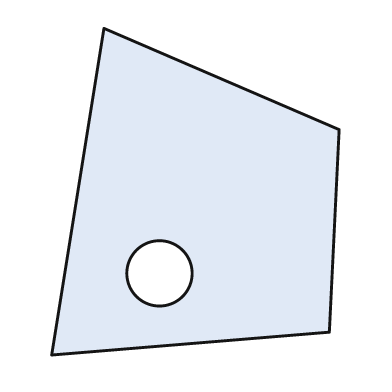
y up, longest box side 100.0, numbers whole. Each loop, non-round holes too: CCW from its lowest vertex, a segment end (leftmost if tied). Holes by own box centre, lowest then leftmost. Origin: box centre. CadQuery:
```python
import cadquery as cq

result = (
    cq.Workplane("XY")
    .moveTo(-44.0, -50.0)
    .lineTo(41.0, -43.0)
    .lineTo(44.0, 19.0)
    .lineTo(-28.0, 50.0)
    .close()
    .moveTo(-11.0, -25.0)
    .circle(10.0)
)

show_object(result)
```